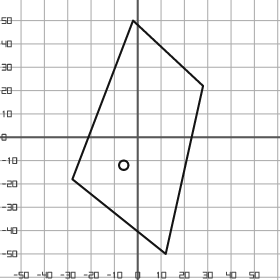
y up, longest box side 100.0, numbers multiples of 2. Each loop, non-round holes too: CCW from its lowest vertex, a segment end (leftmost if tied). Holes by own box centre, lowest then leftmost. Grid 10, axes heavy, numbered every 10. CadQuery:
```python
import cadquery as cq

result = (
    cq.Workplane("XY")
    .moveTo(12.0, -50.0)
    .lineTo(28.0, 22.0)
    .lineTo(-2.0, 50.0)
    .lineTo(-28.0, -18.0)
    .close()
    .moveTo(-6.0, -12.0)
    .circle(2.0)
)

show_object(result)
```